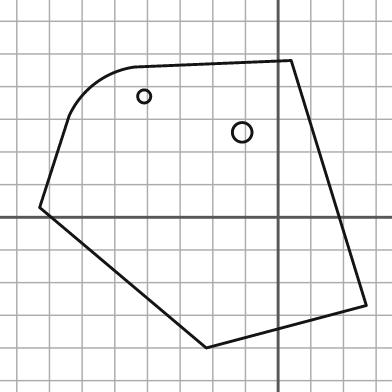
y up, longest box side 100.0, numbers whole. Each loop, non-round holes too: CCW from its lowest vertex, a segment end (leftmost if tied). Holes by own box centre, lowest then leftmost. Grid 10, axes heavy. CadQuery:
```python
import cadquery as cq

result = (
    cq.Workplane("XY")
    .moveTo(-22.0, -40.0)
    .lineTo(27.0, -27.0)
    .lineTo(4.0, 48.0)
    .lineTo(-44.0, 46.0)
    .threePointArc((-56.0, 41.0), (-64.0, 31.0))
    .lineTo(-73.0, 3.0)
    .close()
    .moveTo(-11.0, 26.0)
    .circle(3.0)
    .moveTo(-41.0, 37.0)
    .circle(2.0)
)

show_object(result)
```